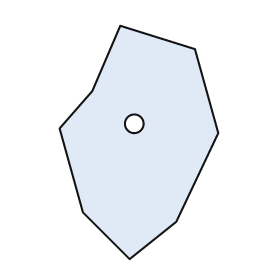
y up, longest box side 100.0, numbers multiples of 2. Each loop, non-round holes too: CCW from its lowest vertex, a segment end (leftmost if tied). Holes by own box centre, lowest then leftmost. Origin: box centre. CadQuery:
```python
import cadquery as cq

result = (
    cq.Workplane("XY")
    .moveTo(-4.0, -50.0)
    .lineTo(16.0, -34.0)
    .lineTo(34.0, 4.0)
    .lineTo(24.0, 40.0)
    .lineTo(-8.0, 50.0)
    .lineTo(-20.0, 22.0)
    .lineTo(-34.0, 6.0)
    .lineTo(-24.0, -30.0)
    .close()
    .moveTo(-2.0, 8.0)
    .circle(4.0)
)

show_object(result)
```